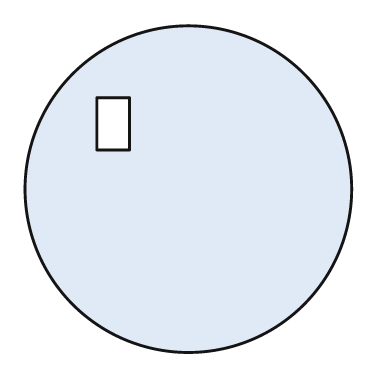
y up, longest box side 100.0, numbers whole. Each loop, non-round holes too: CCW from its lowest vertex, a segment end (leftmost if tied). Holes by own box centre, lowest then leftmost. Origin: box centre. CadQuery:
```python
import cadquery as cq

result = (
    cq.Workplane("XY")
    .moveTo(0.0, 0.0)
    .circle(50.0)
    .moveTo(-28.0, 12.0)
    .lineTo(-18.0, 12.0)
    .lineTo(-18.0, 28.0)
    .lineTo(-28.0, 28.0)
    .close()
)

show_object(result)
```